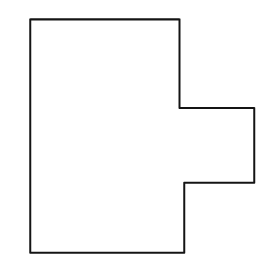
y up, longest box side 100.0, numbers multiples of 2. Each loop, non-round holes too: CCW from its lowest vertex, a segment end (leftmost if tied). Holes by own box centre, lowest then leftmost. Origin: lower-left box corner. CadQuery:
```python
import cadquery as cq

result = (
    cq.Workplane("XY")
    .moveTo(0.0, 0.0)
    .lineTo(66.0, 0.0)
    .lineTo(66.0, 30.0)
    .lineTo(96.0, 30.0)
    .lineTo(96.0, 62.0)
    .lineTo(64.0, 62.0)
    .lineTo(64.0, 100.0)
    .lineTo(0.0, 100.0)
    .close()
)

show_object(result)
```